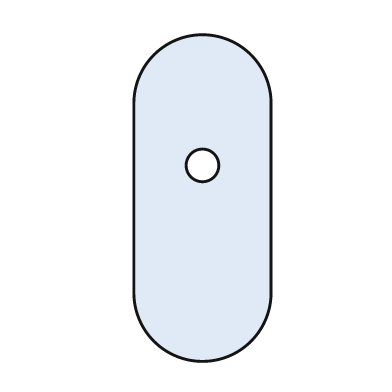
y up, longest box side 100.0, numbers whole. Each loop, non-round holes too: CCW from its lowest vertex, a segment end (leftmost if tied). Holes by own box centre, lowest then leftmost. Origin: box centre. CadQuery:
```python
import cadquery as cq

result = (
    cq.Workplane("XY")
    .moveTo(-21.0, -29.0)
    .threePointArc((0.0, -50.0), (21.0, -29.0))
    .lineTo(21.0, 29.0)
    .threePointArc((0.0, 50.0), (-21.0, 29.0))
    .close()
    .moveTo(0.0, 10.0)
    .circle(5.0)
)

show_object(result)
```